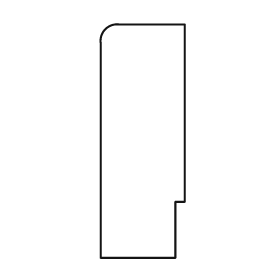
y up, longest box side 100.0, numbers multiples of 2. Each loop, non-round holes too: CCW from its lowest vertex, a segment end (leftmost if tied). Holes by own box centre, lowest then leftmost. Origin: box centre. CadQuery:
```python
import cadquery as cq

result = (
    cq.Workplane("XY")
    .moveTo(-18.0, -50.0)
    .lineTo(14.0, -50.0)
    .lineTo(14.0, -26.0)
    .lineTo(18.0, -26.0)
    .lineTo(18.0, 50.0)
    .lineTo(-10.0, 50.0)
    .threePointArc((-16.0, 48.0), (-18.0, 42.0))
    .close()
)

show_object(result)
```